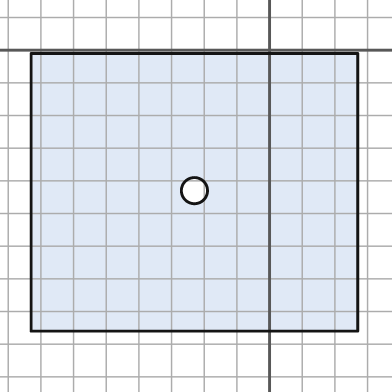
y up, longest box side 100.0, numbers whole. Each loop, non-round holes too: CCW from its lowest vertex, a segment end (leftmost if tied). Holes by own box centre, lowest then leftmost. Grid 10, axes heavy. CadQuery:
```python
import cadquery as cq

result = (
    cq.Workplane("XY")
    .moveTo(-73.0, -86.0)
    .lineTo(27.0, -86.0)
    .lineTo(27.0, -1.0)
    .lineTo(-73.0, -1.0)
    .close()
    .moveTo(-23.0, -43.0)
    .circle(4.0)
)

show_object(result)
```